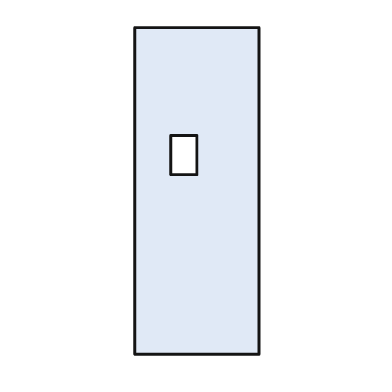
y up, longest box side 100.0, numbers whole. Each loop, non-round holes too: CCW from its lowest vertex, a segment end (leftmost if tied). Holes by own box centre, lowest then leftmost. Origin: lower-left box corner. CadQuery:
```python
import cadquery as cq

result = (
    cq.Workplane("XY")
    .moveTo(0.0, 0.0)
    .lineTo(38.0, 0.0)
    .lineTo(38.0, 100.0)
    .lineTo(0.0, 100.0)
    .close()
    .moveTo(11.0, 55.0)
    .lineTo(19.0, 55.0)
    .lineTo(19.0, 67.0)
    .lineTo(11.0, 67.0)
    .close()
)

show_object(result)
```